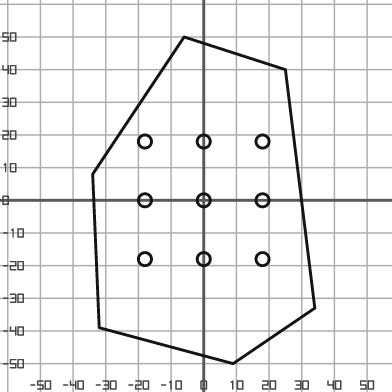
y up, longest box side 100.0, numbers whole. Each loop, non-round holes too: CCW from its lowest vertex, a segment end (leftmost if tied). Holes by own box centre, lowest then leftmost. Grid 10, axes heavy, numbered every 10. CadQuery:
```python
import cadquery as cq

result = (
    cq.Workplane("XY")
    .moveTo(9.0, -50.0)
    .lineTo(34.0, -33.0)
    .lineTo(25.0, 40.0)
    .lineTo(-6.0, 50.0)
    .lineTo(-34.0, 8.0)
    .lineTo(-32.0, -39.0)
    .close()
    .moveTo(-18.0, -18.0)
    .circle(2.0)
    .moveTo(0.0, -18.0)
    .circle(2.0)
    .moveTo(18.0, -18.0)
    .circle(2.0)
    .moveTo(-18.0, 0.0)
    .circle(2.0)
    .moveTo(0.0, 0.0)
    .circle(2.0)
    .moveTo(18.0, 0.0)
    .circle(2.0)
    .moveTo(-18.0, 18.0)
    .circle(2.0)
    .moveTo(0.0, 18.0)
    .circle(2.0)
    .moveTo(18.0, 18.0)
    .circle(2.0)
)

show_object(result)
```